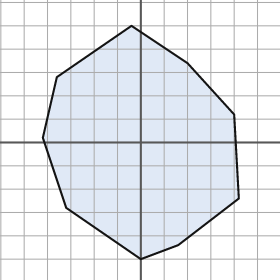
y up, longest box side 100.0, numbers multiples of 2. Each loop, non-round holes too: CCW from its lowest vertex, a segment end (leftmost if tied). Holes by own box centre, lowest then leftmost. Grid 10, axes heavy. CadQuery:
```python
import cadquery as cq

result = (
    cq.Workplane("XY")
    .moveTo(0.0, -50.0)
    .lineTo(16.0, -44.0)
    .lineTo(42.0, -24.0)
    .lineTo(40.0, 12.0)
    .lineTo(20.0, 34.0)
    .lineTo(-4.0, 50.0)
    .lineTo(-36.0, 28.0)
    .lineTo(-42.0, 2.0)
    .lineTo(-32.0, -28.0)
    .close()
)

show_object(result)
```